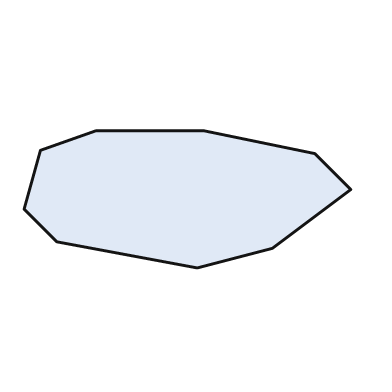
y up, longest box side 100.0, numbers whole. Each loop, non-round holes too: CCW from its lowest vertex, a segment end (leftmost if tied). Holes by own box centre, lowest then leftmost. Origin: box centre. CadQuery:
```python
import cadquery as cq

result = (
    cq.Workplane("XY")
    .moveTo(3.0, -21.0)
    .lineTo(26.0, -15.0)
    .lineTo(50.0, 3.0)
    .lineTo(39.0, 14.0)
    .lineTo(5.0, 21.0)
    .lineTo(-28.0, 21.0)
    .lineTo(-45.0, 15.0)
    .lineTo(-50.0, -3.0)
    .lineTo(-40.0, -13.0)
    .close()
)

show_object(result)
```